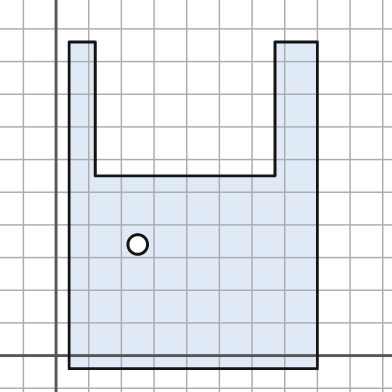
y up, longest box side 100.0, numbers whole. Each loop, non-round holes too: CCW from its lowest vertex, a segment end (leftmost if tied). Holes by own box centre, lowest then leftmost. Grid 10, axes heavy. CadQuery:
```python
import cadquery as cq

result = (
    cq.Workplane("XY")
    .moveTo(4.0, -4.0)
    .lineTo(80.0, -4.0)
    .lineTo(80.0, 96.0)
    .lineTo(67.0, 96.0)
    .lineTo(67.0, 55.0)
    .lineTo(12.0, 55.0)
    .lineTo(12.0, 96.0)
    .lineTo(4.0, 96.0)
    .close()
    .moveTo(25.0, 34.0)
    .circle(3.0)
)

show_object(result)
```